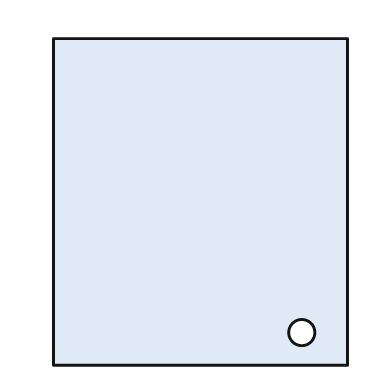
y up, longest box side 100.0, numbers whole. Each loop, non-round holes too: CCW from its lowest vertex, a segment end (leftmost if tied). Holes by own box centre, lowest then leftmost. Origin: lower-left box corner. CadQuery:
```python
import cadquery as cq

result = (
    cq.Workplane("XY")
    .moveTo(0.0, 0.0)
    .lineTo(90.0, 0.0)
    .lineTo(90.0, 100.0)
    .lineTo(0.0, 100.0)
    .close()
    .moveTo(76.0, 10.0)
    .circle(4.0)
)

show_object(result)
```